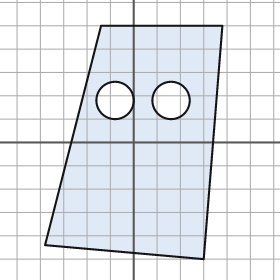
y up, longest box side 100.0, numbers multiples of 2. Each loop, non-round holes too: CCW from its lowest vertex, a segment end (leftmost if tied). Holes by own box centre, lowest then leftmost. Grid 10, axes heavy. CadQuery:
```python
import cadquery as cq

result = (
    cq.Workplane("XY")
    .moveTo(30.0, -50.0)
    .lineTo(38.0, 50.0)
    .lineTo(-14.0, 50.0)
    .lineTo(-38.0, -44.0)
    .close()
    .moveTo(-8.0, 18.0)
    .circle(8.0)
    .moveTo(16.0, 18.0)
    .circle(8.0)
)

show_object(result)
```